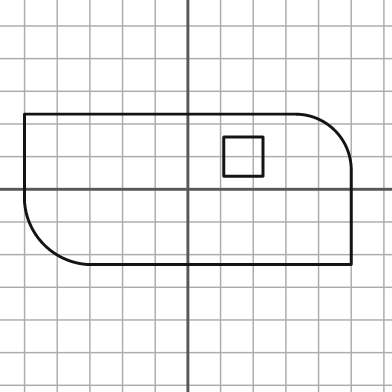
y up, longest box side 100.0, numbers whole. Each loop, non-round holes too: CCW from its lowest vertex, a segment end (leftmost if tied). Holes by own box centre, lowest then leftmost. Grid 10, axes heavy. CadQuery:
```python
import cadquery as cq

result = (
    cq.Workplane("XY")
    .moveTo(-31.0, -23.0)
    .lineTo(50.0, -23.0)
    .lineTo(50.0, 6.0)
    .threePointArc((45.0, 18.0), (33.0, 23.0))
    .lineTo(-50.0, 23.0)
    .lineTo(-50.0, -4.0)
    .threePointArc((-44.0, -17.0), (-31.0, -23.0))
    .close()
    .moveTo(11.0, 4.0)
    .lineTo(23.0, 4.0)
    .lineTo(23.0, 16.0)
    .lineTo(11.0, 16.0)
    .close()
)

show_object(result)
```